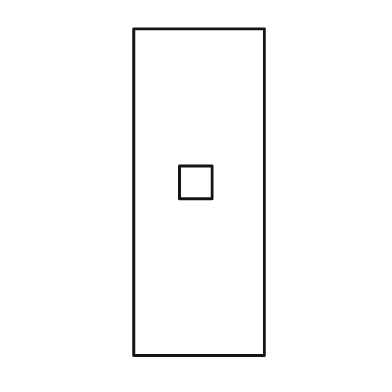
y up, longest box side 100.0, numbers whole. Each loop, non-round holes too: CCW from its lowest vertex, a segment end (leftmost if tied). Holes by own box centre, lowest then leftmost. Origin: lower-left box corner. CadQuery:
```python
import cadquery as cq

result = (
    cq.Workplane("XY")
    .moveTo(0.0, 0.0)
    .lineTo(40.0, 0.0)
    .lineTo(40.0, 100.0)
    .lineTo(0.0, 100.0)
    .close()
    .moveTo(14.0, 48.0)
    .lineTo(24.0, 48.0)
    .lineTo(24.0, 58.0)
    .lineTo(14.0, 58.0)
    .close()
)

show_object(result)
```